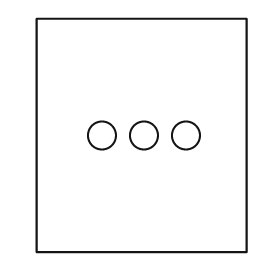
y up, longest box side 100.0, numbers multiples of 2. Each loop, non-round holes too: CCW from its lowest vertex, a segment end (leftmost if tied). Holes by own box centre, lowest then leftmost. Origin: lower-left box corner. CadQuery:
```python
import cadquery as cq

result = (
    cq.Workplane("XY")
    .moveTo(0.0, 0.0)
    .lineTo(90.0, 0.0)
    .lineTo(90.0, 100.0)
    .lineTo(0.0, 100.0)
    .close()
    .moveTo(28.0, 50.0)
    .circle(6.0)
    .moveTo(46.0, 50.0)
    .circle(6.0)
    .moveTo(64.0, 50.0)
    .circle(6.0)
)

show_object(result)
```